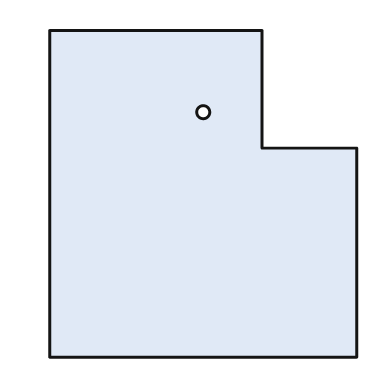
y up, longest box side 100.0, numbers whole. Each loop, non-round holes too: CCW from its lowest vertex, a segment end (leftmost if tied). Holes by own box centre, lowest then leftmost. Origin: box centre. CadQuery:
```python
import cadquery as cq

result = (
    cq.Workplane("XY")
    .moveTo(-47.0, -50.0)
    .lineTo(47.0, -50.0)
    .lineTo(47.0, 14.0)
    .lineTo(18.0, 14.0)
    .lineTo(18.0, 50.0)
    .lineTo(-47.0, 50.0)
    .close()
    .moveTo(0.0, 25.0)
    .circle(2.0)
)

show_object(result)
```